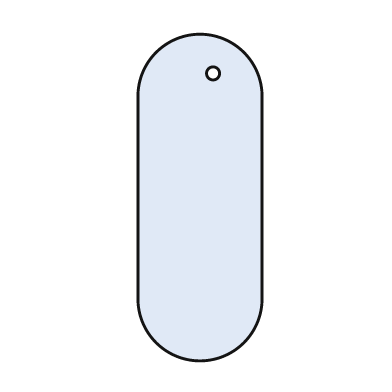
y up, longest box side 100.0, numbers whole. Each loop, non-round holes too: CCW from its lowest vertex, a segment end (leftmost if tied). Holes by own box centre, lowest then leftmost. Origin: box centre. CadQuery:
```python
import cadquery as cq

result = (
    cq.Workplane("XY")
    .moveTo(-19.0, -31.0)
    .threePointArc((0.0, -50.0), (19.0, -31.0))
    .lineTo(19.0, 31.0)
    .threePointArc((0.0, 50.0), (-19.0, 31.0))
    .close()
    .moveTo(4.0, 38.0)
    .circle(2.0)
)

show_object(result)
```